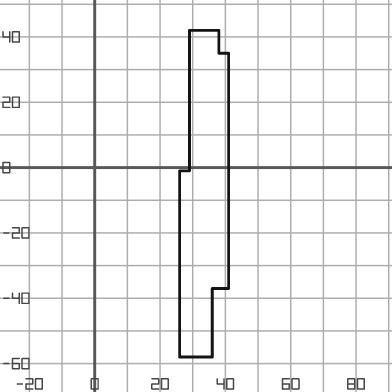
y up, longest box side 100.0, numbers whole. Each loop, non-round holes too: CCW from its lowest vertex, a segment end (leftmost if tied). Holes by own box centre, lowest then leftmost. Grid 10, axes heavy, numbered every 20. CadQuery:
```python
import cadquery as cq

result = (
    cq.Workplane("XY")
    .moveTo(26.0, -58.0)
    .lineTo(36.0, -58.0)
    .lineTo(36.0, -37.0)
    .lineTo(41.0, -37.0)
    .lineTo(41.0, 35.0)
    .lineTo(38.0, 35.0)
    .lineTo(38.0, 42.0)
    .lineTo(29.0, 42.0)
    .lineTo(29.0, -1.0)
    .lineTo(26.0, -1.0)
    .close()
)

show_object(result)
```